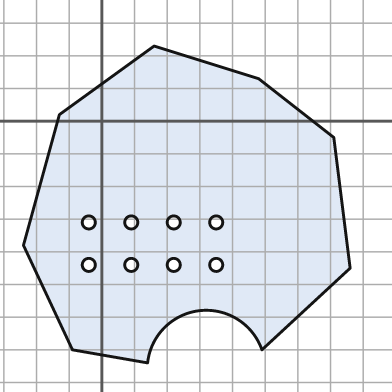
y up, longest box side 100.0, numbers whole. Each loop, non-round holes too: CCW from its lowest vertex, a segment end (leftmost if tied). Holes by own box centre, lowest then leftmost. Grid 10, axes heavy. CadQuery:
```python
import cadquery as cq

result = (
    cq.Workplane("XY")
    .moveTo(14.0, -74.0)
    .threePointArc((30.0, -58.0), (49.0, -70.0))
    .lineTo(76.0, -45.0)
    .lineTo(71.0, -5.0)
    .lineTo(48.0, 13.0)
    .lineTo(16.0, 23.0)
    .lineTo(-13.0, 2.0)
    .lineTo(-24.0, -38.0)
    .lineTo(-9.0, -70.0)
    .close()
    .moveTo(-4.0, -44.0)
    .circle(2.0)
    .moveTo(9.0, -44.0)
    .circle(2.0)
    .moveTo(22.0, -44.0)
    .circle(2.0)
    .moveTo(35.0, -44.0)
    .circle(2.0)
    .moveTo(-4.0, -31.0)
    .circle(2.0)
    .moveTo(9.0, -31.0)
    .circle(2.0)
    .moveTo(22.0, -31.0)
    .circle(2.0)
    .moveTo(35.0, -31.0)
    .circle(2.0)
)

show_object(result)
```